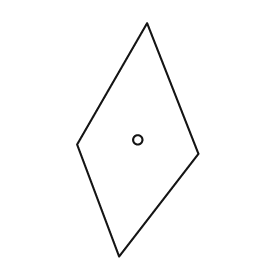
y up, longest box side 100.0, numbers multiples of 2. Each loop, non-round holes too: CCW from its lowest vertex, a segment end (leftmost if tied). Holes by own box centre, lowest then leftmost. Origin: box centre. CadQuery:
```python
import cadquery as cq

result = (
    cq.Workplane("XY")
    .moveTo(-8.0, -50.0)
    .lineTo(26.0, -6.0)
    .lineTo(4.0, 50.0)
    .lineTo(-26.0, -2.0)
    .close()
    .moveTo(0.0, 0.0)
    .circle(2.0)
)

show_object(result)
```